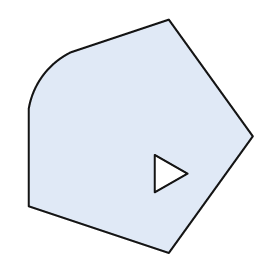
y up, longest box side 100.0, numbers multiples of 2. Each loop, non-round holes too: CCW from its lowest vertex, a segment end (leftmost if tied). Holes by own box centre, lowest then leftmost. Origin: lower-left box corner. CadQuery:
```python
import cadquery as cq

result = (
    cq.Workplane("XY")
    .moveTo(60.0, 0.0)
    .lineTo(96.0, 50.0)
    .lineTo(60.0, 100.0)
    .lineTo(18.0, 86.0)
    .threePointArc((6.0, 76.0), (0.0, 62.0))
    .lineTo(0.0, 20.0)
    .close()
    .moveTo(54.0, 26.0)
    .lineTo(68.0, 34.0)
    .lineTo(54.0, 42.0)
    .close()
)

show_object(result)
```